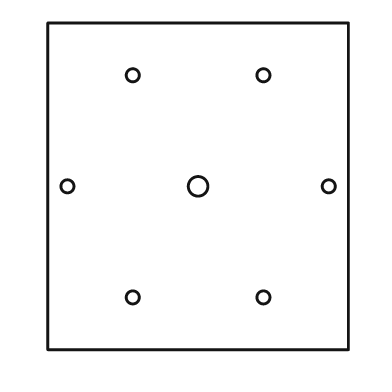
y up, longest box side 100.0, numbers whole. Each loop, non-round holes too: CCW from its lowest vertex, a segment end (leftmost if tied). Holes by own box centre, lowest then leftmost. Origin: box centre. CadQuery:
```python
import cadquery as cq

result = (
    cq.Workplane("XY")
    .moveTo(-46.0, -50.0)
    .lineTo(46.0, -50.0)
    .lineTo(46.0, 50.0)
    .lineTo(-46.0, 50.0)
    .close()
    .moveTo(-20.0, -34.0)
    .circle(2.0)
    .moveTo(20.0, -34.0)
    .circle(2.0)
    .moveTo(-40.0, 0.0)
    .circle(2.0)
    .moveTo(0.0, 0.0)
    .circle(3.0)
    .moveTo(40.0, 0.0)
    .circle(2.0)
    .moveTo(-20.0, 34.0)
    .circle(2.0)
    .moveTo(20.0, 34.0)
    .circle(2.0)
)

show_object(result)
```